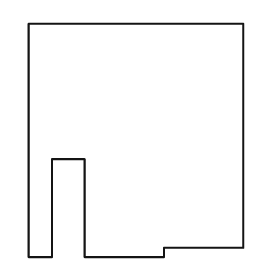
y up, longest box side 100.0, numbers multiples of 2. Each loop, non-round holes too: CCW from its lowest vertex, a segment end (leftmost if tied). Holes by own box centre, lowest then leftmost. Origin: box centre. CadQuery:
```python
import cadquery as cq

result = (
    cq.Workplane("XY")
    .moveTo(-46.0, -50.0)
    .lineTo(-36.0, -50.0)
    .lineTo(-36.0, -8.0)
    .lineTo(-22.0, -8.0)
    .lineTo(-22.0, -50.0)
    .lineTo(12.0, -50.0)
    .lineTo(12.0, -46.0)
    .lineTo(46.0, -46.0)
    .lineTo(46.0, 50.0)
    .lineTo(-46.0, 50.0)
    .close()
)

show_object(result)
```